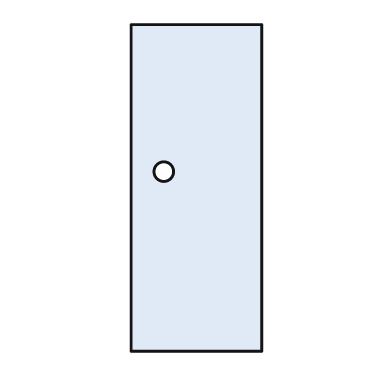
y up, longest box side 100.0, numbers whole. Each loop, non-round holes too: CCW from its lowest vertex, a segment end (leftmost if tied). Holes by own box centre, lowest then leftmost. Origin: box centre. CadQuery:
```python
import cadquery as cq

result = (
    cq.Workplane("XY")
    .moveTo(-20.0, -50.0)
    .lineTo(20.0, -50.0)
    .lineTo(20.0, 50.0)
    .lineTo(-20.0, 50.0)
    .close()
    .moveTo(-10.0, 5.0)
    .circle(3.0)
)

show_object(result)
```